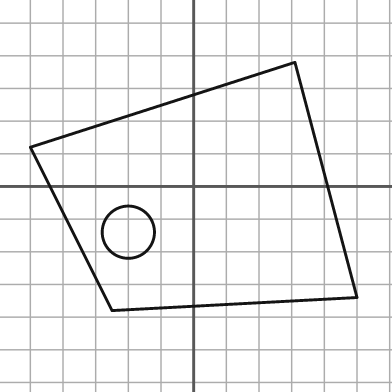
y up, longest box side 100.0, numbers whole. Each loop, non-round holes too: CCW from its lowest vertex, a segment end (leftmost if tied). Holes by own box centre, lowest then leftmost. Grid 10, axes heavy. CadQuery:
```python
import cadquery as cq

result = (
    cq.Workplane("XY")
    .moveTo(-25.0, -38.0)
    .lineTo(50.0, -34.0)
    .lineTo(31.0, 38.0)
    .lineTo(-50.0, 12.0)
    .close()
    .moveTo(-20.0, -14.0)
    .circle(8.0)
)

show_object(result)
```